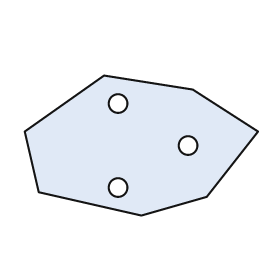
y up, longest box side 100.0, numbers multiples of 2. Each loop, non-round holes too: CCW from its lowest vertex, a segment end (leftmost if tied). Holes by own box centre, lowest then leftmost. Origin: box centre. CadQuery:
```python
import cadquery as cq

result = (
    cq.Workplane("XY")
    .moveTo(0.0, -30.0)
    .lineTo(28.0, -22.0)
    .lineTo(50.0, 6.0)
    .lineTo(22.0, 24.0)
    .lineTo(-16.0, 30.0)
    .lineTo(-50.0, 6.0)
    .lineTo(-44.0, -20.0)
    .close()
    .moveTo(-10.0, -18.0)
    .circle(4.0)
    .moveTo(20.0, 0.0)
    .circle(4.0)
    .moveTo(-10.0, 18.0)
    .circle(4.0)
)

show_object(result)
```